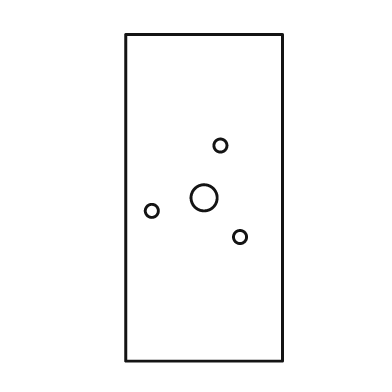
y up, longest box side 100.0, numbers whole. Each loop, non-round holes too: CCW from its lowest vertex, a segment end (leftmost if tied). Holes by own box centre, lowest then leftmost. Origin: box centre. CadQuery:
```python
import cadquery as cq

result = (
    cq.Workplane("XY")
    .moveTo(-24.0, -50.0)
    .lineTo(24.0, -50.0)
    .lineTo(24.0, 50.0)
    .lineTo(-24.0, 50.0)
    .close()
    .moveTo(11.0, -12.0)
    .circle(2.0)
    .moveTo(-16.0, -4.0)
    .circle(2.0)
    .moveTo(0.0, 0.0)
    .circle(4.0)
    .moveTo(5.0, 16.0)
    .circle(2.0)
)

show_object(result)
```